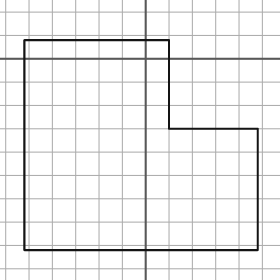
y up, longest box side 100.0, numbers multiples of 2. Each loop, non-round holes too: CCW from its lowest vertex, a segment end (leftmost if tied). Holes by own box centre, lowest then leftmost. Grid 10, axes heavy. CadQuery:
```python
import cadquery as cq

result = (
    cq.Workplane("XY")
    .moveTo(-52.0, -82.0)
    .lineTo(48.0, -82.0)
    .lineTo(48.0, -30.0)
    .lineTo(10.0, -30.0)
    .lineTo(10.0, 8.0)
    .lineTo(-52.0, 8.0)
    .close()
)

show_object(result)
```